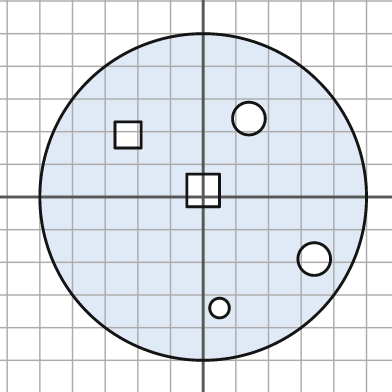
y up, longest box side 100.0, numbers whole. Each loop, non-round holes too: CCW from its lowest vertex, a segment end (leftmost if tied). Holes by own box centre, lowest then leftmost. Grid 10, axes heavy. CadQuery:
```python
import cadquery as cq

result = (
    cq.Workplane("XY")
    .moveTo(0.0, 0.0)
    .circle(50.0)
    .moveTo(5.0, -34.0)
    .circle(3.0)
    .moveTo(34.0, -19.0)
    .circle(5.0)
    .moveTo(-5.0, -3.0)
    .lineTo(5.0, -3.0)
    .lineTo(5.0, 7.0)
    .lineTo(-5.0, 7.0)
    .close()
    .moveTo(-27.0, 15.0)
    .lineTo(-19.0, 15.0)
    .lineTo(-19.0, 23.0)
    .lineTo(-27.0, 23.0)
    .close()
    .moveTo(14.0, 24.0)
    .circle(5.0)
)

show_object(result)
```